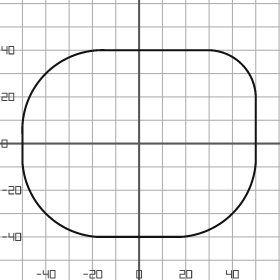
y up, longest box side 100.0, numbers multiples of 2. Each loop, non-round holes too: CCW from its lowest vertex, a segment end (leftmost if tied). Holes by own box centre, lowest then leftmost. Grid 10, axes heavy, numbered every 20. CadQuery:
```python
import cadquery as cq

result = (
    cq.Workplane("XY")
    .moveTo(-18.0, -40.0)
    .lineTo(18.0, -40.0)
    .threePointArc((40.0, -30.0), (50.0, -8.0))
    .lineTo(50.0, 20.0)
    .threePointArc((44.0, 34.0), (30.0, 40.0))
    .lineTo(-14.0, 40.0)
    .threePointArc((-40.0, 30.0), (-50.0, 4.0))
    .lineTo(-50.0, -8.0)
    .threePointArc((-40.0, -30.0), (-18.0, -40.0))
    .close()
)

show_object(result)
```